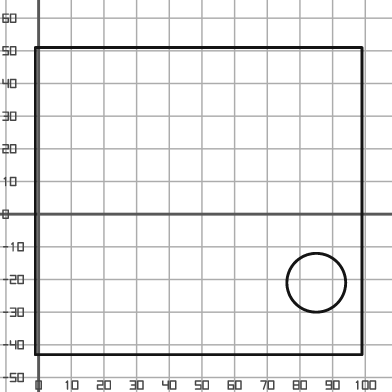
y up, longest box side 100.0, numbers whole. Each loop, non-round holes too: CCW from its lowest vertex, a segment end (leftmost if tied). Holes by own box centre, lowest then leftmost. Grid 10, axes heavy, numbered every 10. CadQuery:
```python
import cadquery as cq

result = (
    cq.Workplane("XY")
    .moveTo(-1.0, -43.0)
    .lineTo(99.0, -43.0)
    .lineTo(99.0, 51.0)
    .lineTo(-1.0, 51.0)
    .close()
    .moveTo(85.0, -21.0)
    .circle(9.0)
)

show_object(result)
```